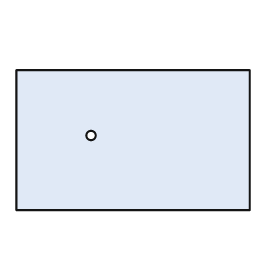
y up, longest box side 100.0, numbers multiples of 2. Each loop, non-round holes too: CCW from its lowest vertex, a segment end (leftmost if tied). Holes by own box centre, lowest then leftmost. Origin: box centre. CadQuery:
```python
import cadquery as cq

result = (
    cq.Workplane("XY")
    .moveTo(-50.0, -30.0)
    .lineTo(50.0, -30.0)
    .lineTo(50.0, 30.0)
    .lineTo(-50.0, 30.0)
    .close()
    .moveTo(-18.0, 2.0)
    .circle(2.0)
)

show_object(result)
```